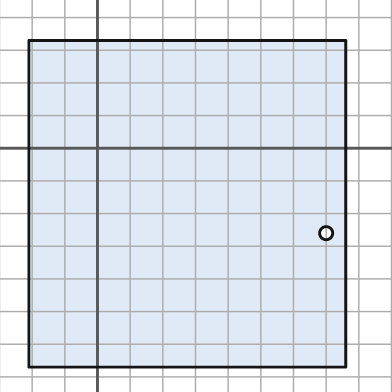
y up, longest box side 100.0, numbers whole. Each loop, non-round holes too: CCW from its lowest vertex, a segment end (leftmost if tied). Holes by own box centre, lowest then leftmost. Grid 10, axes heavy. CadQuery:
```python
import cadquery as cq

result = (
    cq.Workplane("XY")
    .moveTo(-21.0, -67.0)
    .lineTo(76.0, -67.0)
    .lineTo(76.0, 33.0)
    .lineTo(-21.0, 33.0)
    .close()
    .moveTo(70.0, -26.0)
    .circle(2.0)
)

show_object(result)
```